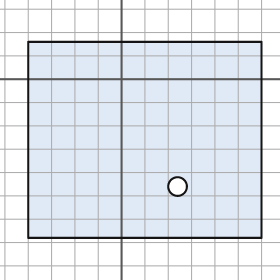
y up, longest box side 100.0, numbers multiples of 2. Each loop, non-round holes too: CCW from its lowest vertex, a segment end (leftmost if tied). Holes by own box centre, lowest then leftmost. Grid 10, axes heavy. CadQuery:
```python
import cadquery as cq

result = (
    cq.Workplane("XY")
    .moveTo(-40.0, -68.0)
    .lineTo(60.0, -68.0)
    .lineTo(60.0, 16.0)
    .lineTo(-40.0, 16.0)
    .close()
    .moveTo(24.0, -46.0)
    .circle(4.0)
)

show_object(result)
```